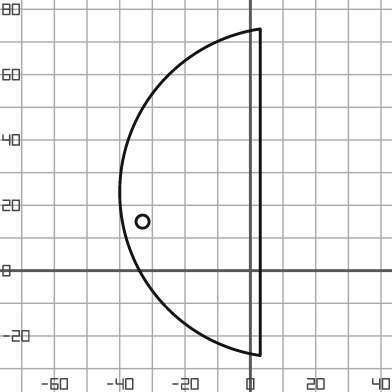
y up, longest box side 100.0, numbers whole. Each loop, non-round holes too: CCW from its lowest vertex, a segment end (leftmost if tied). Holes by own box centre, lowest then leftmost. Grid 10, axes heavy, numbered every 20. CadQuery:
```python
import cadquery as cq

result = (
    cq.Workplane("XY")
    .moveTo(3.0, -26.0)
    .lineTo(3.0, 74.0)
    .threePointArc((-40.0, 24.0), (3.0, -26.0))
    .close()
    .moveTo(-33.0, 15.0)
    .circle(2.0)
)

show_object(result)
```